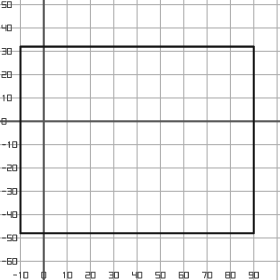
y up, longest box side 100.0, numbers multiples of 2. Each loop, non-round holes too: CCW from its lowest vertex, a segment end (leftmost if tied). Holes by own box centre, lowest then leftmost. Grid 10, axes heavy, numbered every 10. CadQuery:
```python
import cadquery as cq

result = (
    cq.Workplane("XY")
    .moveTo(-10.0, -48.0)
    .lineTo(90.0, -48.0)
    .lineTo(90.0, 32.0)
    .lineTo(-10.0, 32.0)
    .close()
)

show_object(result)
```